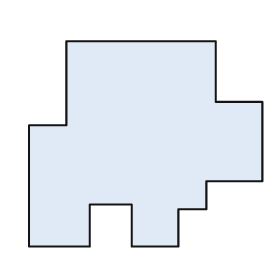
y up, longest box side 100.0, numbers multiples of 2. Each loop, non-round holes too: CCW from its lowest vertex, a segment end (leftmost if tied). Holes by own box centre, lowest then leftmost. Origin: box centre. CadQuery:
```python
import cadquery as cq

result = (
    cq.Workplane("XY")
    .moveTo(-50.0, -44.0)
    .lineTo(-24.0, -44.0)
    .lineTo(-24.0, -26.0)
    .lineTo(-6.0, -26.0)
    .lineTo(-6.0, -44.0)
    .lineTo(14.0, -44.0)
    .lineTo(14.0, -28.0)
    .lineTo(26.0, -28.0)
    .lineTo(26.0, -16.0)
    .lineTo(50.0, -16.0)
    .lineTo(50.0, 18.0)
    .lineTo(30.0, 18.0)
    .lineTo(30.0, 44.0)
    .lineTo(-34.0, 44.0)
    .lineTo(-34.0, 8.0)
    .lineTo(-50.0, 8.0)
    .close()
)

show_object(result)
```